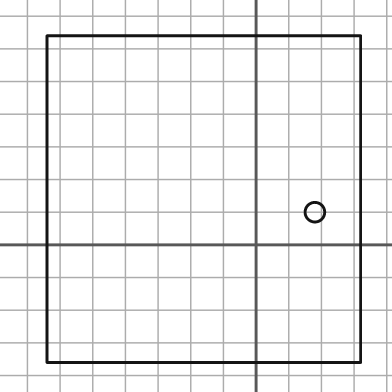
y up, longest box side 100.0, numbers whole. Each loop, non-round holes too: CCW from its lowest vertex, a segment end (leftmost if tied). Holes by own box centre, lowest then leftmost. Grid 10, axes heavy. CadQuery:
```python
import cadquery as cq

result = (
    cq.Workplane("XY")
    .moveTo(-64.0, -36.0)
    .lineTo(32.0, -36.0)
    .lineTo(32.0, 64.0)
    .lineTo(-64.0, 64.0)
    .close()
    .moveTo(18.0, 10.0)
    .circle(3.0)
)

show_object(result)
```